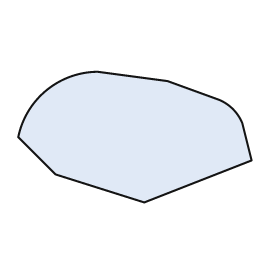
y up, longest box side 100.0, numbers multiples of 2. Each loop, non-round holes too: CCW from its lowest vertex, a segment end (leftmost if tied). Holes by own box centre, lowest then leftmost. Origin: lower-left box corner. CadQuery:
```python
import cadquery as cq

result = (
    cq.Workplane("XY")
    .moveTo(54.0, 0.0)
    .lineTo(100.0, 18.0)
    .lineTo(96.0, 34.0)
    .threePointArc((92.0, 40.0), (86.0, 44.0))
    .lineTo(64.0, 52.0)
    .lineTo(34.0, 56.0)
    .threePointArc((12.0, 48.0), (0.0, 28.0))
    .lineTo(16.0, 12.0)
    .close()
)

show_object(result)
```